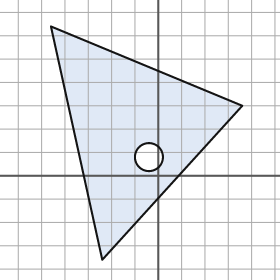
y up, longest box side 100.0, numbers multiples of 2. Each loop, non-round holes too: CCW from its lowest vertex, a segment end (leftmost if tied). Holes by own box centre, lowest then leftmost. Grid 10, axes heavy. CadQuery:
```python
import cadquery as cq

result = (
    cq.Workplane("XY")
    .moveTo(-24.0, -36.0)
    .lineTo(36.0, 30.0)
    .lineTo(-46.0, 64.0)
    .close()
    .moveTo(-4.0, 8.0)
    .circle(6.0)
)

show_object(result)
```